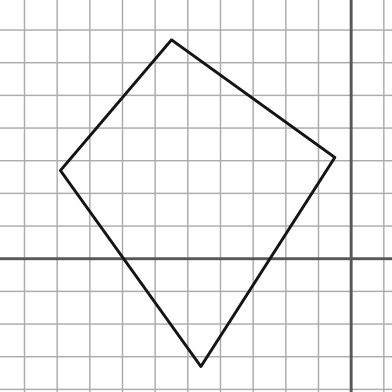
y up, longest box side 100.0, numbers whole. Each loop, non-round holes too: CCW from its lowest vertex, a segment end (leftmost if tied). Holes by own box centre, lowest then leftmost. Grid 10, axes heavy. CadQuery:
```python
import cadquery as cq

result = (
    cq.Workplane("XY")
    .moveTo(-46.0, -33.0)
    .lineTo(-5.0, 31.0)
    .lineTo(-55.0, 67.0)
    .lineTo(-89.0, 27.0)
    .close()
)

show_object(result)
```